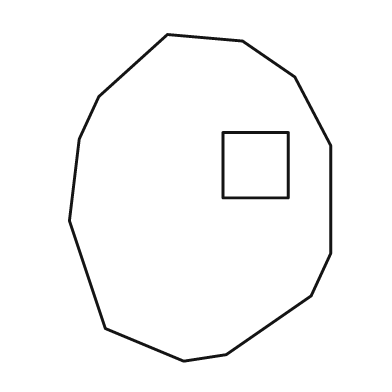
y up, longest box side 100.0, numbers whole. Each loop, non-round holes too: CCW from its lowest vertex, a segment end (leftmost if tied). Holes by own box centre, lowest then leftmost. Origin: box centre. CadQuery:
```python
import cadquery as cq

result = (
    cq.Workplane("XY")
    .moveTo(-5.0, -50.0)
    .lineTo(8.0, -48.0)
    .lineTo(34.0, -30.0)
    .lineTo(40.0, -17.0)
    .lineTo(40.0, 16.0)
    .lineTo(29.0, 37.0)
    .lineTo(13.0, 48.0)
    .lineTo(-10.0, 50.0)
    .lineTo(-31.0, 31.0)
    .lineTo(-37.0, 18.0)
    .lineTo(-40.0, -7.0)
    .lineTo(-29.0, -40.0)
    .close()
    .moveTo(7.0, 0.0)
    .lineTo(27.0, 0.0)
    .lineTo(27.0, 20.0)
    .lineTo(7.0, 20.0)
    .close()
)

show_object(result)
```